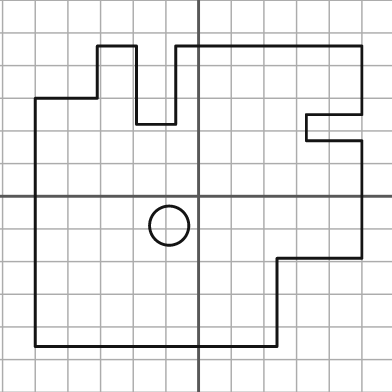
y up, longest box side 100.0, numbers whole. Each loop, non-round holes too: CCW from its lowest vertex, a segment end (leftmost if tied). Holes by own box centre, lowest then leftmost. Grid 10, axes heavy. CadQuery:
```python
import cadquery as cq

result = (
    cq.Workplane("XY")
    .moveTo(-50.0, -46.0)
    .lineTo(24.0, -46.0)
    .lineTo(24.0, -19.0)
    .lineTo(50.0, -19.0)
    .lineTo(50.0, 17.0)
    .lineTo(33.0, 17.0)
    .lineTo(33.0, 25.0)
    .lineTo(50.0, 25.0)
    .lineTo(50.0, 46.0)
    .lineTo(-7.0, 46.0)
    .lineTo(-7.0, 22.0)
    .lineTo(-19.0, 22.0)
    .lineTo(-19.0, 46.0)
    .lineTo(-31.0, 46.0)
    .lineTo(-31.0, 30.0)
    .lineTo(-50.0, 30.0)
    .close()
    .moveTo(-9.0, -9.0)
    .circle(6.0)
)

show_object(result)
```